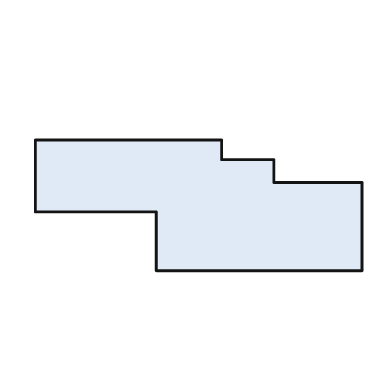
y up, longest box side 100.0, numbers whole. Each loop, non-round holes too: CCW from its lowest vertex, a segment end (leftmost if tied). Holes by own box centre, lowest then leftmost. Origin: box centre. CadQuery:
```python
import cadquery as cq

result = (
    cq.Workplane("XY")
    .moveTo(-13.0, -20.0)
    .lineTo(50.0, -20.0)
    .lineTo(50.0, 7.0)
    .lineTo(23.0, 7.0)
    .lineTo(23.0, 14.0)
    .lineTo(7.0, 14.0)
    .lineTo(7.0, 20.0)
    .lineTo(-50.0, 20.0)
    .lineTo(-50.0, -2.0)
    .lineTo(-13.0, -2.0)
    .close()
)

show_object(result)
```